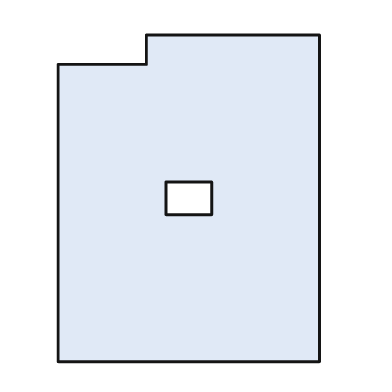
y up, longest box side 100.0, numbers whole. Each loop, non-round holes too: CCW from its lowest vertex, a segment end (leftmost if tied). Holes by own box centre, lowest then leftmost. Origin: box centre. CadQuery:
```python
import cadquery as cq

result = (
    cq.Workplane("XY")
    .moveTo(-40.0, -50.0)
    .lineTo(40.0, -50.0)
    .lineTo(40.0, 50.0)
    .lineTo(-13.0, 50.0)
    .lineTo(-13.0, 41.0)
    .lineTo(-40.0, 41.0)
    .close()
    .moveTo(-7.0, -5.0)
    .lineTo(7.0, -5.0)
    .lineTo(7.0, 5.0)
    .lineTo(-7.0, 5.0)
    .close()
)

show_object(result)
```